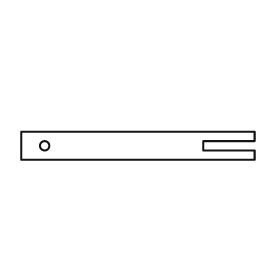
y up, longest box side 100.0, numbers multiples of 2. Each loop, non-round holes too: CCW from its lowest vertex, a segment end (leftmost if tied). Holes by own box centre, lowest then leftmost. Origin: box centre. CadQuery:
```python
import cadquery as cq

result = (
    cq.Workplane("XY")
    .moveTo(-50.0, -6.0)
    .lineTo(50.0, -6.0)
    .lineTo(50.0, -2.0)
    .lineTo(28.0, -2.0)
    .lineTo(28.0, 2.0)
    .lineTo(50.0, 2.0)
    .lineTo(50.0, 6.0)
    .lineTo(-50.0, 6.0)
    .close()
    .moveTo(-40.0, 0.0)
    .circle(2.0)
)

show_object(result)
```